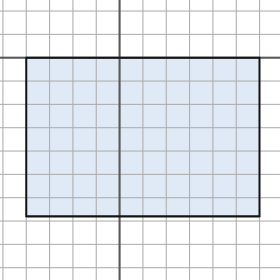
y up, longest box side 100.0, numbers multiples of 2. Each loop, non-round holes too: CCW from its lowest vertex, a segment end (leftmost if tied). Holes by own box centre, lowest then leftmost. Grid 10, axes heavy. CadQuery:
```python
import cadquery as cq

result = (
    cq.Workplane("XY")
    .moveTo(-40.0, -68.0)
    .lineTo(60.0, -68.0)
    .lineTo(60.0, 0.0)
    .lineTo(-40.0, 0.0)
    .close()
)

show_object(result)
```